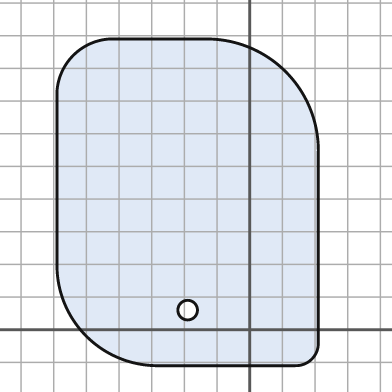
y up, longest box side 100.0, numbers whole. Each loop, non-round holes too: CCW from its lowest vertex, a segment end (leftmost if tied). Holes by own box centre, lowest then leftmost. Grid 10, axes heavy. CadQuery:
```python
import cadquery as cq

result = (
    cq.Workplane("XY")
    .moveTo(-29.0, -11.0)
    .lineTo(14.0, -11.0)
    .threePointArc((19.0, -9.0), (21.0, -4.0))
    .lineTo(21.0, 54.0)
    .threePointArc((11.0, 79.0), (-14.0, 89.0))
    .lineTo(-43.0, 89.0)
    .threePointArc((-54.0, 84.0), (-59.0, 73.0))
    .lineTo(-59.0, 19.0)
    .threePointArc((-50.0, -2.0), (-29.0, -11.0))
    .close()
    .moveTo(-19.0, 6.0)
    .circle(3.0)
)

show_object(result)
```